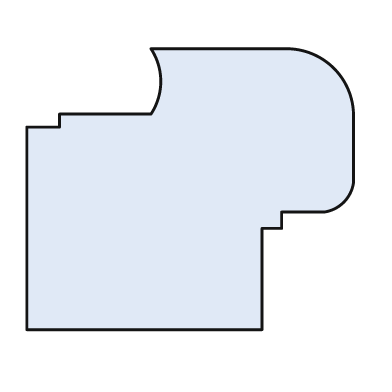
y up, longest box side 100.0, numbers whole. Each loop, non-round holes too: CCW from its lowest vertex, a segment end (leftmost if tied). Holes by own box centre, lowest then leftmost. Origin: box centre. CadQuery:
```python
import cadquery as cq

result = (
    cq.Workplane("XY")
    .moveTo(-50.0, -43.0)
    .lineTo(22.0, -43.0)
    .lineTo(22.0, -12.0)
    .lineTo(28.0, -12.0)
    .lineTo(28.0, -7.0)
    .lineTo(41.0, -7.0)
    .threePointArc((47.0, -4.0), (50.0, 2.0))
    .lineTo(50.0, 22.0)
    .threePointArc((44.0, 37.0), (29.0, 43.0))
    .lineTo(-12.0, 43.0)
    .threePointArc((-9.0, 33.0), (-12.0, 23.0))
    .lineTo(-40.0, 23.0)
    .lineTo(-40.0, 19.0)
    .lineTo(-50.0, 19.0)
    .close()
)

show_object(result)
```